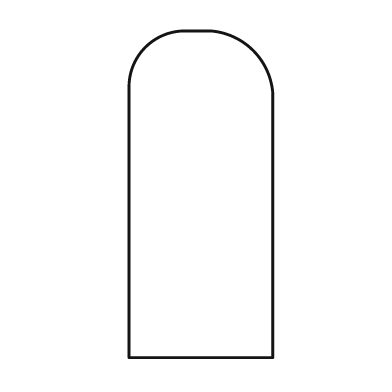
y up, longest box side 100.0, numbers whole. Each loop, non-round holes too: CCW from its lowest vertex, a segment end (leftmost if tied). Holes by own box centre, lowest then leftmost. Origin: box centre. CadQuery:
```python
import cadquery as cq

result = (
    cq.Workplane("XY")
    .moveTo(-22.0, -50.0)
    .lineTo(22.0, -50.0)
    .lineTo(22.0, 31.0)
    .threePointArc((16.0, 44.0), (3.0, 50.0))
    .lineTo(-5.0, 50.0)
    .threePointArc((-17.0, 45.0), (-22.0, 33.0))
    .close()
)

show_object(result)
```